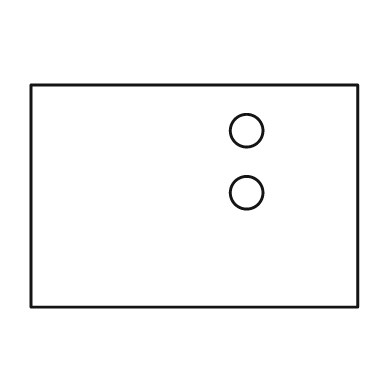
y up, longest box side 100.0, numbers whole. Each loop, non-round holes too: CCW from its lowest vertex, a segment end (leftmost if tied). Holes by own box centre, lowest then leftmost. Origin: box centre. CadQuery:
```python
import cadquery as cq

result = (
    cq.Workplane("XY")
    .moveTo(-50.0, -34.0)
    .lineTo(50.0, -34.0)
    .lineTo(50.0, 34.0)
    .lineTo(-50.0, 34.0)
    .close()
    .moveTo(16.0, 1.0)
    .circle(5.0)
    .moveTo(16.0, 20.0)
    .circle(5.0)
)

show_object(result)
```